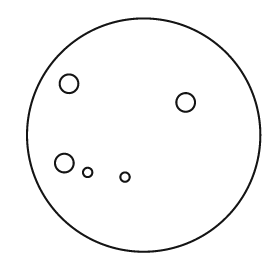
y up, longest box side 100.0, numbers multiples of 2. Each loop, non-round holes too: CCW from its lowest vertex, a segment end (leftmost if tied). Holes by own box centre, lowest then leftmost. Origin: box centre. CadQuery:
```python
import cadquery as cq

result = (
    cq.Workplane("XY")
    .moveTo(0.0, 0.0)
    .circle(50.0)
    .moveTo(-8.0, -18.0)
    .circle(2.0)
    .moveTo(-24.0, -16.0)
    .circle(2.0)
    .moveTo(-34.0, -12.0)
    .circle(4.0)
    .moveTo(18.0, 14.0)
    .circle(4.0)
    .moveTo(-32.0, 22.0)
    .circle(4.0)
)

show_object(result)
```